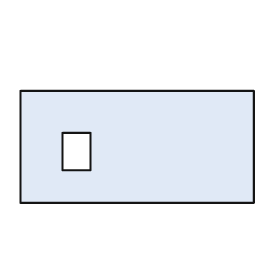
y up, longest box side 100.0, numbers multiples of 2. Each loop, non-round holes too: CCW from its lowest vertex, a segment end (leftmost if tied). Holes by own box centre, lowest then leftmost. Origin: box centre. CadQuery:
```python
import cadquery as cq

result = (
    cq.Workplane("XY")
    .moveTo(-50.0, -24.0)
    .lineTo(50.0, -24.0)
    .lineTo(50.0, 24.0)
    .lineTo(-50.0, 24.0)
    .close()
    .moveTo(-32.0, -10.0)
    .lineTo(-20.0, -10.0)
    .lineTo(-20.0, 6.0)
    .lineTo(-32.0, 6.0)
    .close()
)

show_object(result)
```